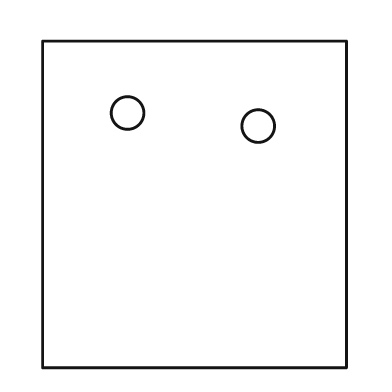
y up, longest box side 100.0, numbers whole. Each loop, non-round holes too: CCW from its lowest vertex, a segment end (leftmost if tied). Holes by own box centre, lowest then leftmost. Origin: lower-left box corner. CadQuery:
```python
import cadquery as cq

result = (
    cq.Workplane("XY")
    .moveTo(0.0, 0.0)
    .lineTo(93.0, 0.0)
    .lineTo(93.0, 100.0)
    .lineTo(0.0, 100.0)
    .close()
    .moveTo(66.0, 74.0)
    .circle(5.0)
    .moveTo(26.0, 78.0)
    .circle(5.0)
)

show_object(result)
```